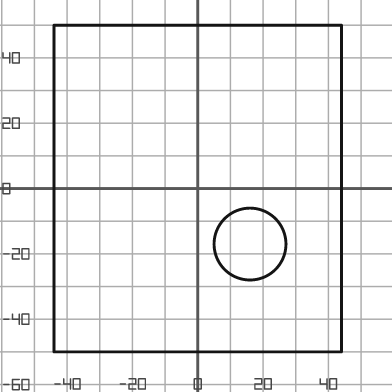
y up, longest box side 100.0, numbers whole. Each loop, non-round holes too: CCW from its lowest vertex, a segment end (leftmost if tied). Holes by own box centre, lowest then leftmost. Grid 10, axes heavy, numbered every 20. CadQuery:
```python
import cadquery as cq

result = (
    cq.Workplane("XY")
    .moveTo(-44.0, -50.0)
    .lineTo(44.0, -50.0)
    .lineTo(44.0, 50.0)
    .lineTo(-44.0, 50.0)
    .close()
    .moveTo(16.0, -17.0)
    .circle(11.0)
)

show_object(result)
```